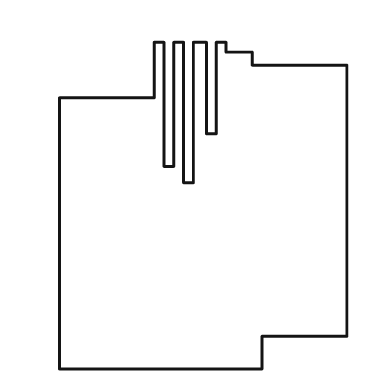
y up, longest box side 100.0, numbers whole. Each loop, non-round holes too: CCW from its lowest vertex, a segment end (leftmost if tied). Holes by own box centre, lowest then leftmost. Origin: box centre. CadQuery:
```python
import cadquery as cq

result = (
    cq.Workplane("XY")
    .moveTo(-44.0, -50.0)
    .lineTo(18.0, -50.0)
    .lineTo(18.0, -40.0)
    .lineTo(44.0, -40.0)
    .lineTo(44.0, 43.0)
    .lineTo(15.0, 43.0)
    .lineTo(15.0, 47.0)
    .lineTo(7.0, 47.0)
    .lineTo(7.0, 50.0)
    .lineTo(4.0, 50.0)
    .lineTo(4.0, 22.0)
    .lineTo(1.0, 22.0)
    .lineTo(1.0, 50.0)
    .lineTo(-3.0, 50.0)
    .lineTo(-3.0, 7.0)
    .lineTo(-6.0, 7.0)
    .lineTo(-6.0, 50.0)
    .lineTo(-9.0, 50.0)
    .lineTo(-9.0, 12.0)
    .lineTo(-12.0, 12.0)
    .lineTo(-12.0, 50.0)
    .lineTo(-15.0, 50.0)
    .lineTo(-15.0, 33.0)
    .lineTo(-44.0, 33.0)
    .close()
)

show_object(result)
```